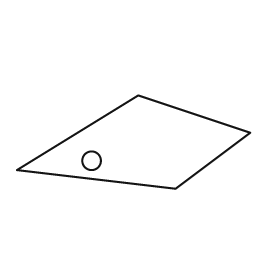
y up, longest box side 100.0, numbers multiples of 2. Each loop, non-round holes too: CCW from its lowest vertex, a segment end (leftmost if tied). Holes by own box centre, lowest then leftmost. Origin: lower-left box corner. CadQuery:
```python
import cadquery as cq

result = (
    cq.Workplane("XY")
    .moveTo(68.0, 0.0)
    .lineTo(100.0, 24.0)
    .lineTo(52.0, 40.0)
    .lineTo(0.0, 8.0)
    .close()
    .moveTo(32.0, 12.0)
    .circle(4.0)
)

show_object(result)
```